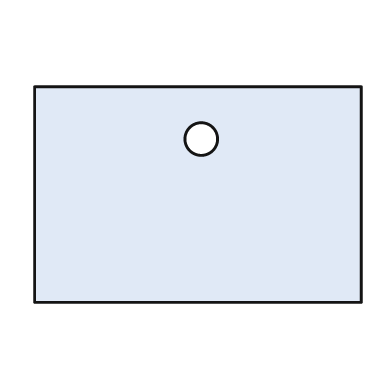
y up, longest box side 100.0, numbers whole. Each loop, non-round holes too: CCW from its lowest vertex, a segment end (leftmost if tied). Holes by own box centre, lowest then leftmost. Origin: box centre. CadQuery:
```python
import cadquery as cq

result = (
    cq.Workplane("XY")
    .moveTo(-50.0, -33.0)
    .lineTo(50.0, -33.0)
    .lineTo(50.0, 33.0)
    .lineTo(-50.0, 33.0)
    .close()
    .moveTo(1.0, 17.0)
    .circle(5.0)
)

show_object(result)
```